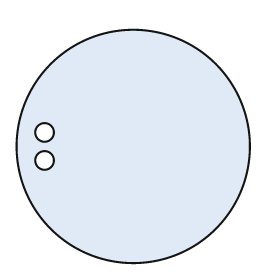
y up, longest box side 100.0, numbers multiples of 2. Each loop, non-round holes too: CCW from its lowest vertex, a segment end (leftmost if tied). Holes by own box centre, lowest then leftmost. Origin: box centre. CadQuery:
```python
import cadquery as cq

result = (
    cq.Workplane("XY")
    .moveTo(0.0, 0.0)
    .circle(50.0)
    .moveTo(-38.0, -6.0)
    .circle(4.0)
    .moveTo(-38.0, 6.0)
    .circle(4.0)
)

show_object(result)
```